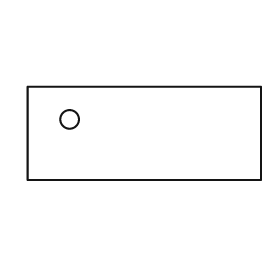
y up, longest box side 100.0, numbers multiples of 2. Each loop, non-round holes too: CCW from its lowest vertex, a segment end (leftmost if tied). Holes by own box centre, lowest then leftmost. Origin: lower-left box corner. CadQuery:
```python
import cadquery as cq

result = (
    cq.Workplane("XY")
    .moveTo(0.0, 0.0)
    .lineTo(100.0, 0.0)
    .lineTo(100.0, 40.0)
    .lineTo(0.0, 40.0)
    .close()
    .moveTo(18.0, 26.0)
    .circle(4.0)
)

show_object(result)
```